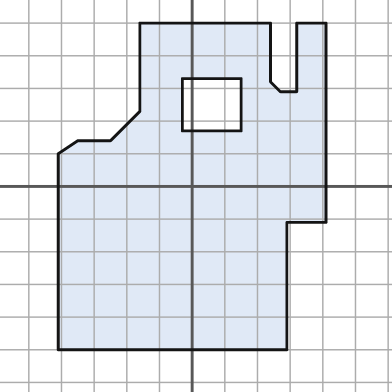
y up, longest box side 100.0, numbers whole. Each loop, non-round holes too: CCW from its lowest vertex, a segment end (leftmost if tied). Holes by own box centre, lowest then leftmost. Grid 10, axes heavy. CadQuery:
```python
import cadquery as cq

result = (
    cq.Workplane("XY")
    .moveTo(-41.0, -50.0)
    .lineTo(29.0, -50.0)
    .lineTo(29.0, -11.0)
    .lineTo(41.0, -11.0)
    .lineTo(41.0, 50.0)
    .lineTo(32.0, 50.0)
    .lineTo(32.0, 29.0)
    .lineTo(27.0, 29.0)
    .lineTo(24.0, 32.0)
    .lineTo(24.0, 50.0)
    .lineTo(-16.0, 50.0)
    .lineTo(-16.0, 23.0)
    .lineTo(-25.0, 14.0)
    .lineTo(-35.0, 14.0)
    .lineTo(-41.0, 10.0)
    .close()
    .moveTo(-3.0, 17.0)
    .lineTo(15.0, 17.0)
    .lineTo(15.0, 33.0)
    .lineTo(-3.0, 33.0)
    .close()
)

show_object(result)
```